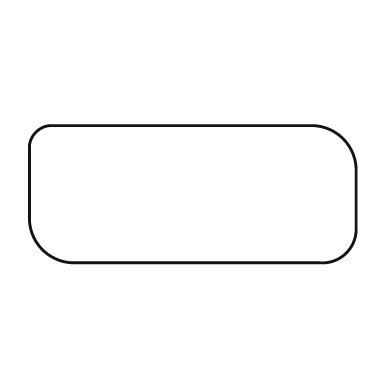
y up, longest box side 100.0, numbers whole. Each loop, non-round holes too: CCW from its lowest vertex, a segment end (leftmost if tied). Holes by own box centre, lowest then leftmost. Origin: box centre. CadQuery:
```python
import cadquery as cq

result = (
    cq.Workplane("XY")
    .moveTo(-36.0, -21.0)
    .lineTo(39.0, -21.0)
    .threePointArc((47.0, -18.0), (50.0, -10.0))
    .lineTo(50.0, 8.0)
    .threePointArc((46.0, 17.0), (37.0, 21.0))
    .lineTo(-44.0, 21.0)
    .threePointArc((-48.0, 19.0), (-50.0, 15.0))
    .lineTo(-50.0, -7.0)
    .threePointArc((-46.0, -17.0), (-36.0, -21.0))
    .close()
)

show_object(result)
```